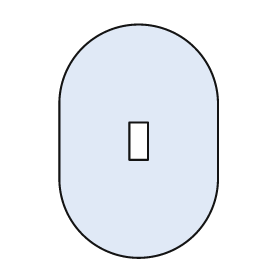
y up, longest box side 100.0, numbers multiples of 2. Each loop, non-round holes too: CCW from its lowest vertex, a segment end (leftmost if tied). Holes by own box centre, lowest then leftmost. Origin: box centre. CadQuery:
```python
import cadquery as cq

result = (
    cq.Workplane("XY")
    .moveTo(-34.0, -16.0)
    .threePointArc((0.0, -50.0), (34.0, -16.0))
    .lineTo(34.0, 16.0)
    .threePointArc((0.0, 50.0), (-34.0, 16.0))
    .close()
    .moveTo(-4.0, -8.0)
    .lineTo(4.0, -8.0)
    .lineTo(4.0, 8.0)
    .lineTo(-4.0, 8.0)
    .close()
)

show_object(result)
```